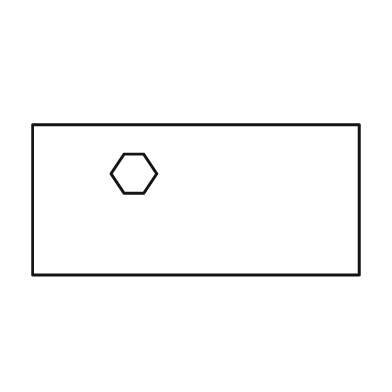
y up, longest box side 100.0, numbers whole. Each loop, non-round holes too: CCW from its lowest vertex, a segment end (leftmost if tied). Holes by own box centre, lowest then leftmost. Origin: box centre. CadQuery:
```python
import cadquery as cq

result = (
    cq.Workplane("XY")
    .moveTo(-50.0, -23.0)
    .lineTo(50.0, -23.0)
    .lineTo(50.0, 23.0)
    .lineTo(-50.0, 23.0)
    .close()
    .moveTo(-22.0, 2.0)
    .lineTo(-16.0, 2.0)
    .lineTo(-12.0, 8.0)
    .lineTo(-16.0, 14.0)
    .lineTo(-22.0, 14.0)
    .lineTo(-26.0, 8.0)
    .close()
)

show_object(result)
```